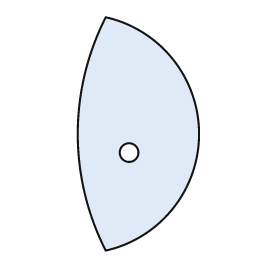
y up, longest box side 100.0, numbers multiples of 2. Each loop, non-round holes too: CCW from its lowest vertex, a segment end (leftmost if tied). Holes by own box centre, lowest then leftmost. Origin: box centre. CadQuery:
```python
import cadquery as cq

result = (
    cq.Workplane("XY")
    .moveTo(-14.0, -50.0)
    .threePointArc((26.0, 0.0), (-14.0, 50.0))
    .threePointArc((-26.0, 0.0), (-14.0, -50.0))
    .close()
    .moveTo(-4.0, -8.0)
    .circle(4.0)
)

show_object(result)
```